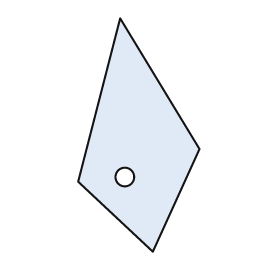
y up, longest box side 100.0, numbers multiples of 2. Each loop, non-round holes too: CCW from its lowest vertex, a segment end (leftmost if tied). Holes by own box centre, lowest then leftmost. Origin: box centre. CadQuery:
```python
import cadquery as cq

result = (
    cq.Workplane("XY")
    .moveTo(6.0, -50.0)
    .lineTo(26.0, -6.0)
    .lineTo(-8.0, 50.0)
    .lineTo(-26.0, -20.0)
    .close()
    .moveTo(-6.0, -18.0)
    .circle(4.0)
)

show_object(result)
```